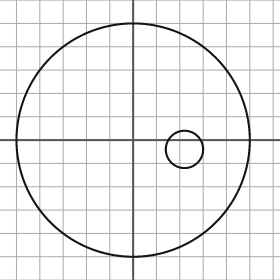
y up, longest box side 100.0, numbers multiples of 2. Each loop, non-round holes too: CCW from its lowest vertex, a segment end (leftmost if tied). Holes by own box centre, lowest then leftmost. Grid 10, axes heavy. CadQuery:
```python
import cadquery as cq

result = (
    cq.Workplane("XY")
    .moveTo(0.0, 0.0)
    .circle(50.0)
    .moveTo(22.0, -4.0)
    .circle(8.0)
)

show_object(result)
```